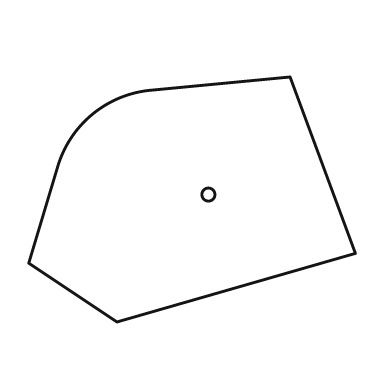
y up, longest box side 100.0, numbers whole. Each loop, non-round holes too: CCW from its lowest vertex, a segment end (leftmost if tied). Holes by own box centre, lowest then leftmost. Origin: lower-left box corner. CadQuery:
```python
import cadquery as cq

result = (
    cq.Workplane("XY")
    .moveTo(27.0, 0.0)
    .lineTo(100.0, 21.0)
    .lineTo(80.0, 75.0)
    .lineTo(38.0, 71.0)
    .threePointArc((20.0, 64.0), (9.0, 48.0))
    .lineTo(0.0, 18.0)
    .close()
    .moveTo(55.0, 39.0)
    .circle(2.0)
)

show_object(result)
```